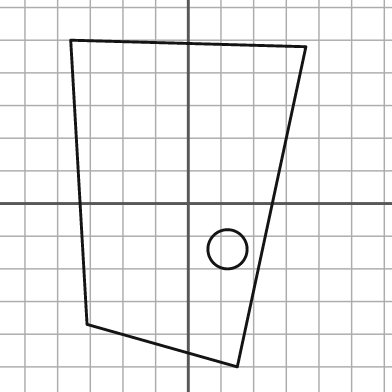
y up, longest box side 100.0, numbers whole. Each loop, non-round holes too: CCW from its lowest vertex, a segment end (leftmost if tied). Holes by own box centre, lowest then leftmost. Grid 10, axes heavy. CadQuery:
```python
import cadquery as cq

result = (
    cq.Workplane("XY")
    .moveTo(15.0, -50.0)
    .lineTo(36.0, 48.0)
    .lineTo(-36.0, 50.0)
    .lineTo(-31.0, -37.0)
    .close()
    .moveTo(12.0, -14.0)
    .circle(6.0)
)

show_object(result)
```